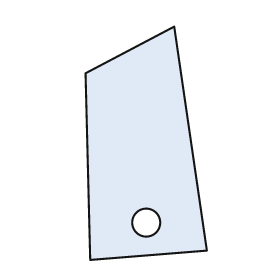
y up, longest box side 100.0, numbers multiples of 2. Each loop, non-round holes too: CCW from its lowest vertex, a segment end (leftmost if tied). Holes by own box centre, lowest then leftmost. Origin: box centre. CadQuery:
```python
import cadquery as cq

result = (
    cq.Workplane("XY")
    .moveTo(-24.0, -50.0)
    .lineTo(26.0, -46.0)
    .lineTo(12.0, 50.0)
    .lineTo(-26.0, 30.0)
    .close()
    .moveTo(0.0, -34.0)
    .circle(6.0)
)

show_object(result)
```